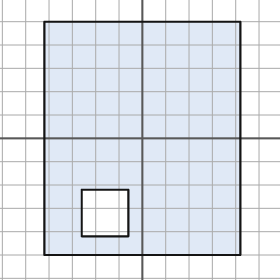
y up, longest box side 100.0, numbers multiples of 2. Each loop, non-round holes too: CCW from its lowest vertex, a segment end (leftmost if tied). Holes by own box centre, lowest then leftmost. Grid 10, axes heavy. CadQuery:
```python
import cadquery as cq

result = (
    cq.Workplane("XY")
    .moveTo(-42.0, -50.0)
    .lineTo(42.0, -50.0)
    .lineTo(42.0, 50.0)
    .lineTo(-42.0, 50.0)
    .close()
    .moveTo(-26.0, -42.0)
    .lineTo(-6.0, -42.0)
    .lineTo(-6.0, -22.0)
    .lineTo(-26.0, -22.0)
    .close()
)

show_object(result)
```